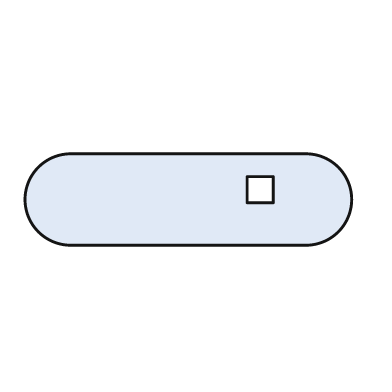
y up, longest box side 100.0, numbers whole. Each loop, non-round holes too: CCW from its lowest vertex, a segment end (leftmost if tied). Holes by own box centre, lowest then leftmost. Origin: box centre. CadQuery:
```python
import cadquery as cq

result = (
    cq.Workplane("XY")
    .moveTo(-36.0, -14.0)
    .lineTo(36.0, -14.0)
    .threePointArc((50.0, 0.0), (36.0, 14.0))
    .lineTo(-36.0, 14.0)
    .threePointArc((-50.0, 0.0), (-36.0, -14.0))
    .close()
    .moveTo(18.0, -1.0)
    .lineTo(26.0, -1.0)
    .lineTo(26.0, 7.0)
    .lineTo(18.0, 7.0)
    .close()
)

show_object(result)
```